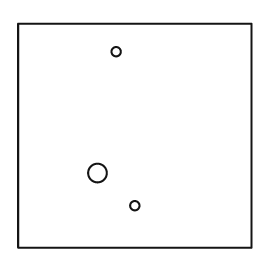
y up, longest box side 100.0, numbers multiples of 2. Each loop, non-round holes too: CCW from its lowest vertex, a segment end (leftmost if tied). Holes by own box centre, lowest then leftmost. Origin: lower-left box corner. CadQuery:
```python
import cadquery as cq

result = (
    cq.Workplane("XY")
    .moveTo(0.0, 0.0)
    .lineTo(100.0, 0.0)
    .lineTo(100.0, 96.0)
    .lineTo(0.0, 96.0)
    .close()
    .moveTo(50.0, 18.0)
    .circle(2.0)
    .moveTo(34.0, 32.0)
    .circle(4.0)
    .moveTo(42.0, 84.0)
    .circle(2.0)
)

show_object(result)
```